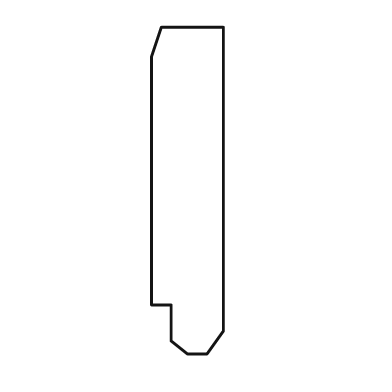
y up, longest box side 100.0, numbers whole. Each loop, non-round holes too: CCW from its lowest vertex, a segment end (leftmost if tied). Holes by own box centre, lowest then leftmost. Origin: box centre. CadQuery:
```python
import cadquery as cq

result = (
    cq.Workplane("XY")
    .moveTo(0.0, -50.0)
    .lineTo(6.0, -50.0)
    .lineTo(11.0, -43.0)
    .lineTo(11.0, 50.0)
    .lineTo(-8.0, 50.0)
    .lineTo(-11.0, 41.0)
    .lineTo(-11.0, -35.0)
    .lineTo(-5.0, -35.0)
    .lineTo(-5.0, -46.0)
    .close()
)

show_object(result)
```